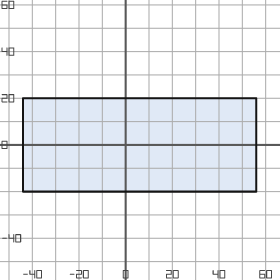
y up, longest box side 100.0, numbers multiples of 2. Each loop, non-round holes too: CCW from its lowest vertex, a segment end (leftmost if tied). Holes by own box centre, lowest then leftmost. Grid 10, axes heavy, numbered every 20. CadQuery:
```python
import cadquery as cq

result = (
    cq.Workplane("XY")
    .moveTo(-44.0, -20.0)
    .lineTo(56.0, -20.0)
    .lineTo(56.0, 20.0)
    .lineTo(-44.0, 20.0)
    .close()
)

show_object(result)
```